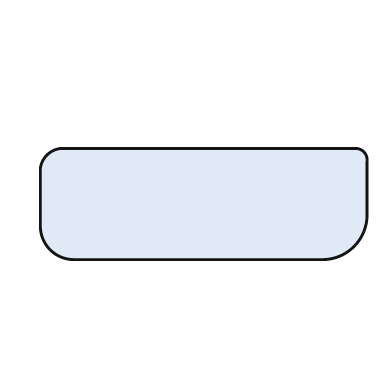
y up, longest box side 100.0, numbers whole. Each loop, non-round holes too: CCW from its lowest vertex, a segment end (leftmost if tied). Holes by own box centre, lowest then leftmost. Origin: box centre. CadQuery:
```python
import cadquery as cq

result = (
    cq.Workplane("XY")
    .moveTo(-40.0, -17.0)
    .lineTo(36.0, -17.0)
    .threePointArc((46.0, -13.0), (50.0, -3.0))
    .lineTo(50.0, 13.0)
    .threePointArc((49.0, 16.0), (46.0, 17.0))
    .lineTo(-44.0, 17.0)
    .threePointArc((-48.0, 15.0), (-50.0, 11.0))
    .lineTo(-50.0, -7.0)
    .threePointArc((-47.0, -14.0), (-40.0, -17.0))
    .close()
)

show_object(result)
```